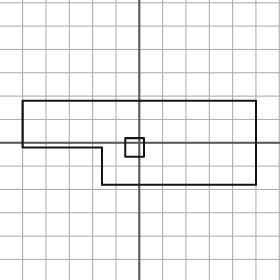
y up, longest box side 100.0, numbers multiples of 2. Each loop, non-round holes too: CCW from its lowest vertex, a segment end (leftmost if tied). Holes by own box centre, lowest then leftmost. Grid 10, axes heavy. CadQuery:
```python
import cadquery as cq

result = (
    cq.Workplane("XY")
    .moveTo(-16.0, -18.0)
    .lineTo(50.0, -18.0)
    .lineTo(50.0, 18.0)
    .lineTo(-50.0, 18.0)
    .lineTo(-50.0, -2.0)
    .lineTo(-16.0, -2.0)
    .close()
    .moveTo(-6.0, -6.0)
    .lineTo(2.0, -6.0)
    .lineTo(2.0, 2.0)
    .lineTo(-6.0, 2.0)
    .close()
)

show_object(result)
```